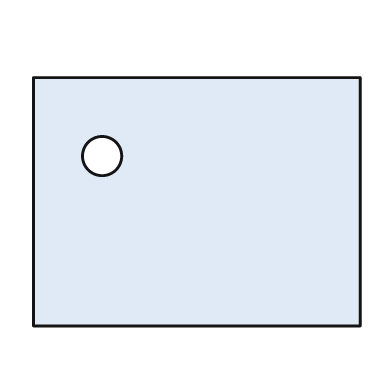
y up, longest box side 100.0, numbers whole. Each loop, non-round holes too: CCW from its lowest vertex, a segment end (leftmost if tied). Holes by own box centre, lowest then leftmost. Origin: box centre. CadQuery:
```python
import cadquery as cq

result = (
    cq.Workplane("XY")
    .moveTo(-50.0, -38.0)
    .lineTo(50.0, -38.0)
    .lineTo(50.0, 38.0)
    .lineTo(-50.0, 38.0)
    .close()
    .moveTo(-29.0, 14.0)
    .circle(6.0)
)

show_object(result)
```